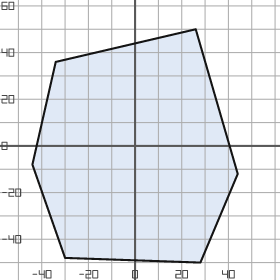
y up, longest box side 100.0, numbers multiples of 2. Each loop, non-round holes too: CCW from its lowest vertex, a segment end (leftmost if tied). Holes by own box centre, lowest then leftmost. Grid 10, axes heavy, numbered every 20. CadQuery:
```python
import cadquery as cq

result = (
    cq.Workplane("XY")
    .moveTo(28.0, -50.0)
    .lineTo(44.0, -12.0)
    .lineTo(26.0, 50.0)
    .lineTo(-34.0, 36.0)
    .lineTo(-44.0, -8.0)
    .lineTo(-30.0, -48.0)
    .close()
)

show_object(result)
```